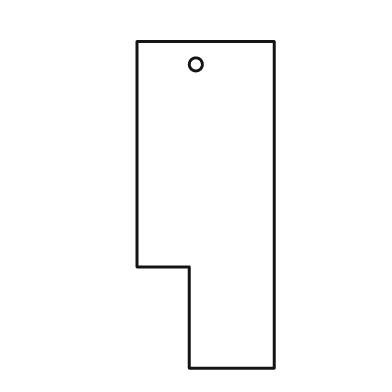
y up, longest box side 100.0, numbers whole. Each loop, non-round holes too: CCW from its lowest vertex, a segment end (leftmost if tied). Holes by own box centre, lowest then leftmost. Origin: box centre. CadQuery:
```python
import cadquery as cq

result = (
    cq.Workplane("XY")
    .moveTo(-5.0, -50.0)
    .lineTo(21.0, -50.0)
    .lineTo(21.0, 50.0)
    .lineTo(-21.0, 50.0)
    .lineTo(-21.0, -19.0)
    .lineTo(-5.0, -19.0)
    .close()
    .moveTo(-3.0, 43.0)
    .circle(2.0)
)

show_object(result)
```